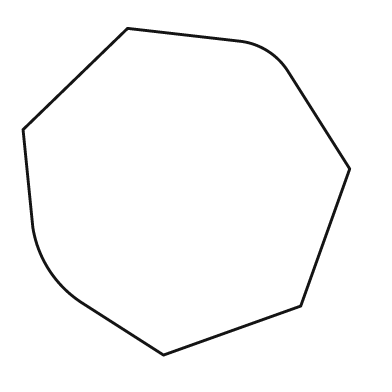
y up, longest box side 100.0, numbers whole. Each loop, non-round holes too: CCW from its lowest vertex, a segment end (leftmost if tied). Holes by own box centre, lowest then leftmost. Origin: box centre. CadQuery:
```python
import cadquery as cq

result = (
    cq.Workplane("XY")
    .moveTo(-7.0, -50.0)
    .lineTo(35.0, -35.0)
    .lineTo(50.0, 7.0)
    .lineTo(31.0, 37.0)
    .threePointArc((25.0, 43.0), (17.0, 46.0))
    .lineTo(-18.0, 50.0)
    .lineTo(-50.0, 19.0)
    .lineTo(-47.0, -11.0)
    .threePointArc((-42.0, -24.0), (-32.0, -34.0))
    .close()
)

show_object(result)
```